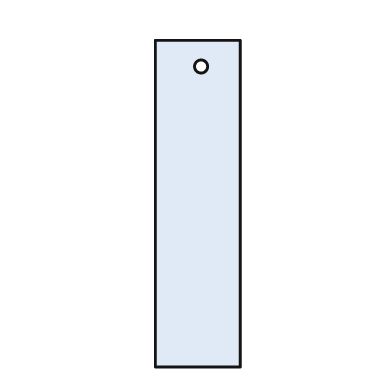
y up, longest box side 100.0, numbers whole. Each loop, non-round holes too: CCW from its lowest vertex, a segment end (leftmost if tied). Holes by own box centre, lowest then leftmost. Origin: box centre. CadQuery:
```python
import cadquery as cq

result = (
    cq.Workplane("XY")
    .moveTo(-13.0, -50.0)
    .lineTo(13.0, -50.0)
    .lineTo(13.0, 50.0)
    .lineTo(-13.0, 50.0)
    .close()
    .moveTo(1.0, 42.0)
    .circle(2.0)
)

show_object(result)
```